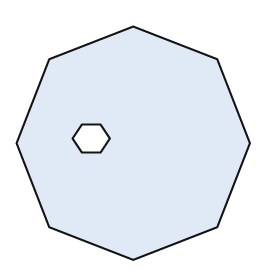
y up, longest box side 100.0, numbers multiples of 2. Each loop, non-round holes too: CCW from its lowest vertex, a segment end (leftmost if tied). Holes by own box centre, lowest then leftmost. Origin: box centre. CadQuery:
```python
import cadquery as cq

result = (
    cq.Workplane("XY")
    .moveTo(0.0, -50.0)
    .lineTo(36.0, -36.0)
    .lineTo(50.0, 0.0)
    .lineTo(36.0, 36.0)
    .lineTo(0.0, 50.0)
    .lineTo(-36.0, 36.0)
    .lineTo(-50.0, 0.0)
    .lineTo(-36.0, -36.0)
    .close()
    .moveTo(-22.0, -4.0)
    .lineTo(-14.0, -4.0)
    .lineTo(-10.0, 2.0)
    .lineTo(-14.0, 8.0)
    .lineTo(-22.0, 8.0)
    .lineTo(-26.0, 2.0)
    .close()
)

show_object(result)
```